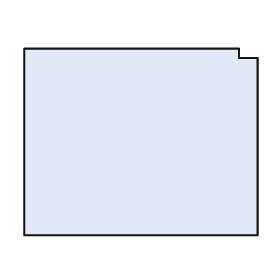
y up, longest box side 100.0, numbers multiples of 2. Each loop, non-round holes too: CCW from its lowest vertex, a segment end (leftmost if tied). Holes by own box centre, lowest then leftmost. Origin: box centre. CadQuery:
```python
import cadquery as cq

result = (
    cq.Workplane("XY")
    .moveTo(-50.0, -40.0)
    .lineTo(50.0, -40.0)
    .lineTo(50.0, 36.0)
    .lineTo(42.0, 36.0)
    .lineTo(42.0, 40.0)
    .lineTo(-50.0, 40.0)
    .close()
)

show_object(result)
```